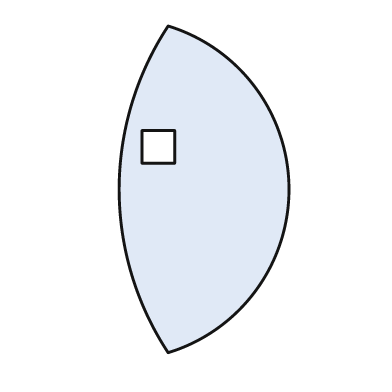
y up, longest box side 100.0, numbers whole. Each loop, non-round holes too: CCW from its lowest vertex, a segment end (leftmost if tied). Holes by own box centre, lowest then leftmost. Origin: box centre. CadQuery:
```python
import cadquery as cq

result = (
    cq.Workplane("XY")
    .moveTo(-11.0, -50.0)
    .threePointArc((26.0, 0.0), (-11.0, 50.0))
    .threePointArc((-26.0, 0.0), (-11.0, -50.0))
    .close()
    .moveTo(-19.0, 8.0)
    .lineTo(-9.0, 8.0)
    .lineTo(-9.0, 18.0)
    .lineTo(-19.0, 18.0)
    .close()
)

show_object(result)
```